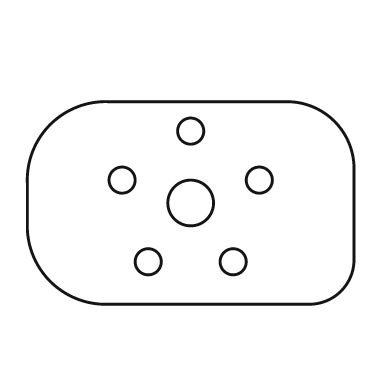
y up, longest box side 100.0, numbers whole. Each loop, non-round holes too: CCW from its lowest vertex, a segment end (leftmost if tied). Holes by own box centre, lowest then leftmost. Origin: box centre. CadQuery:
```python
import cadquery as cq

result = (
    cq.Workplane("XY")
    .moveTo(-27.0, -31.0)
    .lineTo(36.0, -31.0)
    .threePointArc((46.0, -27.0), (50.0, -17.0))
    .lineTo(50.0, 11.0)
    .threePointArc((44.0, 25.0), (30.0, 31.0))
    .lineTo(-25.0, 31.0)
    .threePointArc((-43.0, 24.0), (-50.0, 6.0))
    .lineTo(-50.0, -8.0)
    .threePointArc((-43.0, -24.0), (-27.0, -31.0))
    .close()
    .moveTo(-13.0, -18.0)
    .circle(4.0)
    .moveTo(13.0, -18.0)
    .circle(4.0)
    .moveTo(0.0, 0.0)
    .circle(7.0)
    .moveTo(-21.0, 7.0)
    .circle(4.0)
    .moveTo(21.0, 7.0)
    .circle(4.0)
    .moveTo(0.0, 22.0)
    .circle(4.0)
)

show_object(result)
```